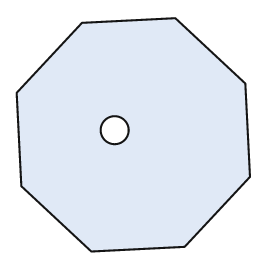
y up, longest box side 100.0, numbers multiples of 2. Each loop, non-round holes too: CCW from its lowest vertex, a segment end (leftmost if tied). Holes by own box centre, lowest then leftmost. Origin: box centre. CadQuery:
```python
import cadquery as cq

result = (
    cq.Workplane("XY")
    .moveTo(-18.0, -50.0)
    .lineTo(22.0, -48.0)
    .lineTo(50.0, -18.0)
    .lineTo(48.0, 22.0)
    .lineTo(18.0, 50.0)
    .lineTo(-22.0, 48.0)
    .lineTo(-50.0, 18.0)
    .lineTo(-48.0, -22.0)
    .close()
    .moveTo(-8.0, 2.0)
    .circle(6.0)
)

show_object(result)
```